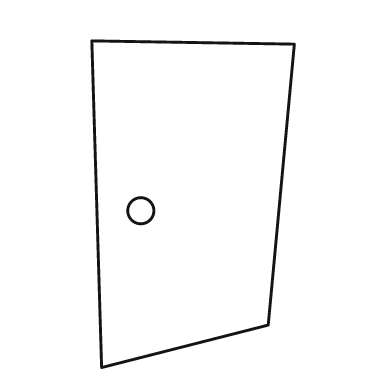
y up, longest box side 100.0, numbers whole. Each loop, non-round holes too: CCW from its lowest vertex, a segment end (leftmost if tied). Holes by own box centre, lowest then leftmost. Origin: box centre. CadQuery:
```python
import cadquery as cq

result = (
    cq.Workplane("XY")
    .moveTo(-28.0, -50.0)
    .lineTo(23.0, -37.0)
    .lineTo(31.0, 49.0)
    .lineTo(-31.0, 50.0)
    .close()
    .moveTo(-16.0, -2.0)
    .circle(4.0)
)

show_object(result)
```